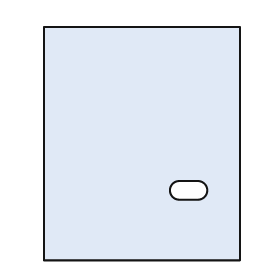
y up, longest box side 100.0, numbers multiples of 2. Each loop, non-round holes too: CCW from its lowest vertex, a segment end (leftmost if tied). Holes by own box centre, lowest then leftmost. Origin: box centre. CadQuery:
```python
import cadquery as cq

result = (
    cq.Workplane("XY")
    .moveTo(-42.0, -50.0)
    .lineTo(42.0, -50.0)
    .lineTo(42.0, 50.0)
    .lineTo(-42.0, 50.0)
    .close()
    .moveTo(16.0, -24.0)
    .lineTo(24.0, -24.0)
    .threePointArc((28.0, -20.0), (24.0, -16.0))
    .lineTo(16.0, -16.0)
    .threePointArc((12.0, -20.0), (16.0, -24.0))
    .close()
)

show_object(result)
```